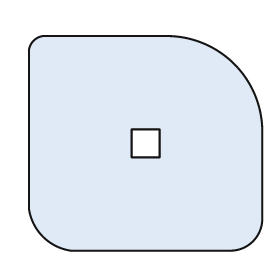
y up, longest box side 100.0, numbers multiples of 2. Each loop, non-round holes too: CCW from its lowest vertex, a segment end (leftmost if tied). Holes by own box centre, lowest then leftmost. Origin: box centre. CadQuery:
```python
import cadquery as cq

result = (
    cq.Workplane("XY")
    .moveTo(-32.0, -46.0)
    .lineTo(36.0, -46.0)
    .threePointArc((46.0, -42.0), (50.0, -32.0))
    .lineTo(50.0, 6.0)
    .threePointArc((38.0, 34.0), (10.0, 46.0))
    .lineTo(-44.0, 46.0)
    .threePointArc((-48.0, 44.0), (-50.0, 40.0))
    .lineTo(-50.0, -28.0)
    .threePointArc((-44.0, -40.0), (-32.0, -46.0))
    .close()
    .moveTo(-6.0, -6.0)
    .lineTo(6.0, -6.0)
    .lineTo(6.0, 6.0)
    .lineTo(-6.0, 6.0)
    .close()
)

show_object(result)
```